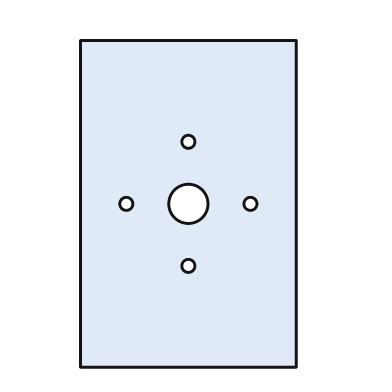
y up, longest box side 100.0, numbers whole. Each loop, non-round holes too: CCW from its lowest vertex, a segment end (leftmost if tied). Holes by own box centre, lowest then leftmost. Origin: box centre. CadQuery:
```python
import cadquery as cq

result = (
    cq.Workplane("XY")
    .moveTo(-33.0, -50.0)
    .lineTo(33.0, -50.0)
    .lineTo(33.0, 50.0)
    .lineTo(-33.0, 50.0)
    .close()
    .moveTo(0.0, -19.0)
    .circle(2.0)
    .moveTo(-19.0, 0.0)
    .circle(2.0)
    .moveTo(0.0, 0.0)
    .circle(6.0)
    .moveTo(19.0, 0.0)
    .circle(2.0)
    .moveTo(0.0, 19.0)
    .circle(2.0)
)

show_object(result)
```